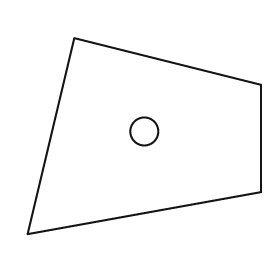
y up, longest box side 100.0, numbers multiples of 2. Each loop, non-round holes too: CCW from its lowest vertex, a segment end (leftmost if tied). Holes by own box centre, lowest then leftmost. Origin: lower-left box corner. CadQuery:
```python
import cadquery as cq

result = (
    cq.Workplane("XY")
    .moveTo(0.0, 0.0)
    .lineTo(100.0, 18.0)
    .lineTo(100.0, 64.0)
    .lineTo(20.0, 84.0)
    .close()
    .moveTo(50.0, 44.0)
    .circle(6.0)
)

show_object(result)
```